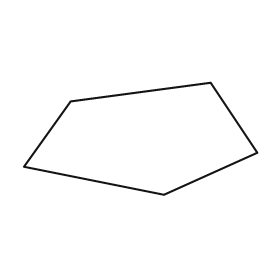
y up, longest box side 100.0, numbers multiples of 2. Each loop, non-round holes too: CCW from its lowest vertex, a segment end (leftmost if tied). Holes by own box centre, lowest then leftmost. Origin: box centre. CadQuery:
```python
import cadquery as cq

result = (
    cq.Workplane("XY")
    .moveTo(10.0, -24.0)
    .lineTo(50.0, -6.0)
    .lineTo(30.0, 24.0)
    .lineTo(-30.0, 16.0)
    .lineTo(-50.0, -12.0)
    .close()
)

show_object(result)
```